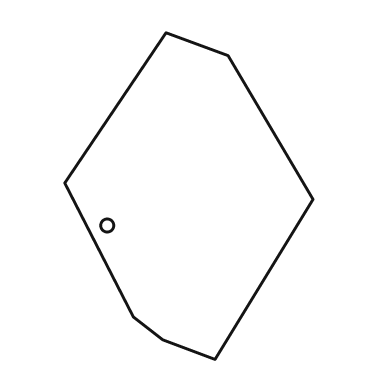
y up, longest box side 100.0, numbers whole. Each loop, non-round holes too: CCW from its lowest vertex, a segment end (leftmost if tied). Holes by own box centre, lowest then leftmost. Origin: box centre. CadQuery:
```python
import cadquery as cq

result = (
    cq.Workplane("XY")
    .moveTo(8.0, -50.0)
    .lineTo(38.0, -1.0)
    .lineTo(12.0, 43.0)
    .lineTo(-7.0, 50.0)
    .lineTo(-38.0, 4.0)
    .lineTo(-17.0, -37.0)
    .lineTo(-8.0, -44.0)
    .close()
    .moveTo(-25.0, -9.0)
    .circle(2.0)
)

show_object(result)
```